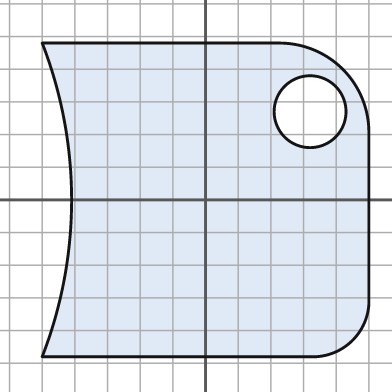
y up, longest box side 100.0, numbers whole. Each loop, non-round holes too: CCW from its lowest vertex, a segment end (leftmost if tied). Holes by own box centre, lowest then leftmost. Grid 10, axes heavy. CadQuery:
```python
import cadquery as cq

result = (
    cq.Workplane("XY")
    .moveTo(-50.0, -48.0)
    .lineTo(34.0, -48.0)
    .threePointArc((45.0, -43.0), (50.0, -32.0))
    .lineTo(50.0, 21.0)
    .threePointArc((42.0, 40.0), (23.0, 48.0))
    .lineTo(-50.0, 48.0)
    .threePointArc((-41.0, 0.0), (-50.0, -48.0))
    .close()
    .moveTo(32.0, 27.0)
    .circle(11.0)
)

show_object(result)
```